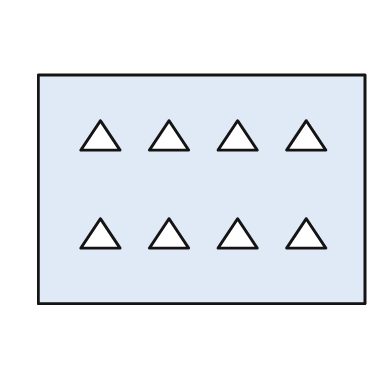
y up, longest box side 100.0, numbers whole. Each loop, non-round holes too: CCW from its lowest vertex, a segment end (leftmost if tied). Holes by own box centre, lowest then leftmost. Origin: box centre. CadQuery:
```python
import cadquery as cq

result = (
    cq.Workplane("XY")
    .moveTo(-50.0, -35.0)
    .lineTo(50.0, -35.0)
    .lineTo(50.0, 35.0)
    .lineTo(-50.0, 35.0)
    .close()
    .moveTo(-37.0, -18.0)
    .lineTo(-25.0, -18.0)
    .lineTo(-31.0, -9.0)
    .close()
    .moveTo(-16.0, -18.0)
    .lineTo(-4.0, -18.0)
    .lineTo(-10.0, -9.0)
    .close()
    .moveTo(5.0, -18.0)
    .lineTo(17.0, -18.0)
    .lineTo(11.0, -9.0)
    .close()
    .moveTo(26.0, -18.0)
    .lineTo(38.0, -18.0)
    .lineTo(32.0, -9.0)
    .close()
    .moveTo(-37.0, 12.0)
    .lineTo(-25.0, 12.0)
    .lineTo(-31.0, 21.0)
    .close()
    .moveTo(-16.0, 12.0)
    .lineTo(-4.0, 12.0)
    .lineTo(-10.0, 21.0)
    .close()
    .moveTo(5.0, 12.0)
    .lineTo(17.0, 12.0)
    .lineTo(11.0, 21.0)
    .close()
    .moveTo(26.0, 12.0)
    .lineTo(38.0, 12.0)
    .lineTo(32.0, 21.0)
    .close()
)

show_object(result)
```